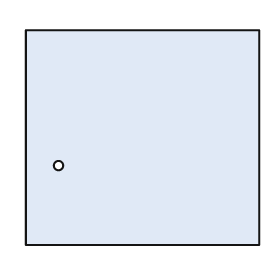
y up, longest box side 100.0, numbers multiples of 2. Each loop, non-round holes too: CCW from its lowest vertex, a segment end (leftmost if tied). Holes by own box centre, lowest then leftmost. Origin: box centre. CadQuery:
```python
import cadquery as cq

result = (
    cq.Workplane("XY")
    .moveTo(-50.0, -46.0)
    .lineTo(50.0, -46.0)
    .lineTo(50.0, 46.0)
    .lineTo(-50.0, 46.0)
    .close()
    .moveTo(-36.0, -12.0)
    .circle(2.0)
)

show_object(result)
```